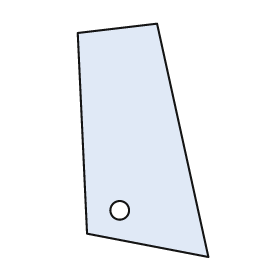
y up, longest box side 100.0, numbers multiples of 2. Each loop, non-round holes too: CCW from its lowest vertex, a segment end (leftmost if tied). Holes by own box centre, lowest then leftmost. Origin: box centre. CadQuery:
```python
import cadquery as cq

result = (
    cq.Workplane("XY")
    .moveTo(28.0, -50.0)
    .lineTo(6.0, 50.0)
    .lineTo(-28.0, 46.0)
    .lineTo(-24.0, -40.0)
    .close()
    .moveTo(-10.0, -30.0)
    .circle(4.0)
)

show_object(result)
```